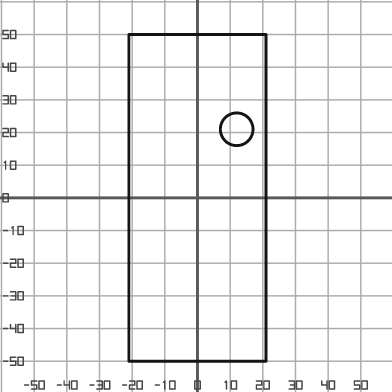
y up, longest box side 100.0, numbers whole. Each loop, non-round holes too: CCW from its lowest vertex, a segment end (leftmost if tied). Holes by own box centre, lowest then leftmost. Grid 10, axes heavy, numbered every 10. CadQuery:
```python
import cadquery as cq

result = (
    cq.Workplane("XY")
    .moveTo(-21.0, -50.0)
    .lineTo(21.0, -50.0)
    .lineTo(21.0, 50.0)
    .lineTo(-21.0, 50.0)
    .close()
    .moveTo(12.0, 21.0)
    .circle(5.0)
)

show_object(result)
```